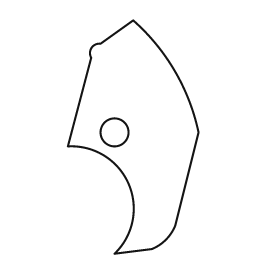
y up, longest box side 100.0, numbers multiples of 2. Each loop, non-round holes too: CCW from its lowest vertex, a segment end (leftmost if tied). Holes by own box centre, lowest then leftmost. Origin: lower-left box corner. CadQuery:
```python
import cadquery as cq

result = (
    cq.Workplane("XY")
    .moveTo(20.0, 0.0)
    .lineTo(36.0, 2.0)
    .threePointArc((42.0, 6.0), (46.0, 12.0))
    .lineTo(56.0, 52.0)
    .threePointArc((46.0, 78.0), (28.0, 100.0))
    .lineTo(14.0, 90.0)
    .threePointArc((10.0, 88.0), (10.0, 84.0))
    .lineTo(0.0, 46.0)
    .threePointArc((26.0, 30.0), (20.0, 0.0))
    .close()
    .moveTo(20.0, 52.0)
    .circle(6.0)
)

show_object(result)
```